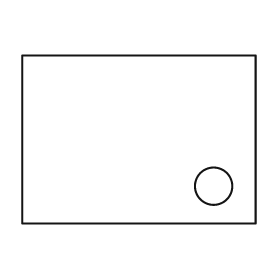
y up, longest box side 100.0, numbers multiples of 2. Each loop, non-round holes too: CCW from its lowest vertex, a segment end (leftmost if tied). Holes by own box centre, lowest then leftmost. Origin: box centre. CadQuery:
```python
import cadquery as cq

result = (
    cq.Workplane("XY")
    .moveTo(-50.0, -36.0)
    .lineTo(50.0, -36.0)
    .lineTo(50.0, 36.0)
    .lineTo(-50.0, 36.0)
    .close()
    .moveTo(32.0, -20.0)
    .circle(8.0)
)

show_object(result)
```